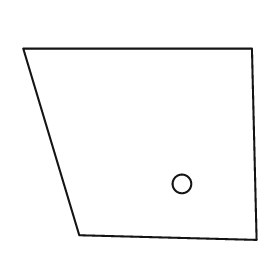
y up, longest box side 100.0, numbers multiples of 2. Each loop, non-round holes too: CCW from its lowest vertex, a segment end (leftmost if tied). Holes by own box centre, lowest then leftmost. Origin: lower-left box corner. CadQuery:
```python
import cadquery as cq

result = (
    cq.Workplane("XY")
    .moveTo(100.0, 0.0)
    .lineTo(98.0, 82.0)
    .lineTo(0.0, 82.0)
    .lineTo(24.0, 2.0)
    .close()
    .moveTo(68.0, 24.0)
    .circle(4.0)
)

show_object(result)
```